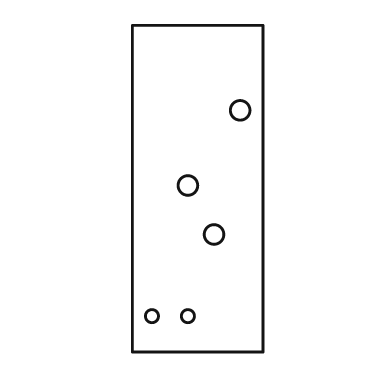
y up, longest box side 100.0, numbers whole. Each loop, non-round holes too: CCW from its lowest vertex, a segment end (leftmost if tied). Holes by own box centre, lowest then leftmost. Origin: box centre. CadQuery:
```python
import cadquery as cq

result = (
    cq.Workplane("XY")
    .moveTo(-20.0, -50.0)
    .lineTo(20.0, -50.0)
    .lineTo(20.0, 50.0)
    .lineTo(-20.0, 50.0)
    .close()
    .moveTo(-14.0, -39.0)
    .circle(2.0)
    .moveTo(-3.0, -39.0)
    .circle(2.0)
    .moveTo(5.0, -14.0)
    .circle(3.0)
    .moveTo(-3.0, 1.0)
    .circle(3.0)
    .moveTo(13.0, 24.0)
    .circle(3.0)
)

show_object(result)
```